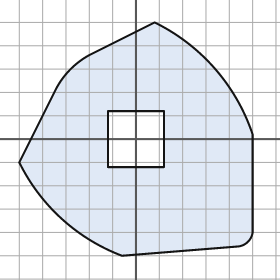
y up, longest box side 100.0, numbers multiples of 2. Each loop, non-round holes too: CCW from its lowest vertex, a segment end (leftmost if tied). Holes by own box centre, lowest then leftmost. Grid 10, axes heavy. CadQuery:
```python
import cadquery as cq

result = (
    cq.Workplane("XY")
    .moveTo(-6.0, -50.0)
    .lineTo(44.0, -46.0)
    .threePointArc((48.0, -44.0), (50.0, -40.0))
    .lineTo(50.0, 2.0)
    .threePointArc((34.0, 30.0), (8.0, 50.0))
    .lineTo(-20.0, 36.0)
    .threePointArc((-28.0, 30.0), (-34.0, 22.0))
    .lineTo(-50.0, -10.0)
    .threePointArc((-32.0, -34.0), (-6.0, -50.0))
    .close()
    .moveTo(-12.0, -12.0)
    .lineTo(12.0, -12.0)
    .lineTo(12.0, 12.0)
    .lineTo(-12.0, 12.0)
    .close()
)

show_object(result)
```